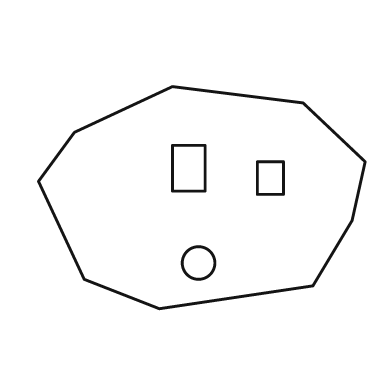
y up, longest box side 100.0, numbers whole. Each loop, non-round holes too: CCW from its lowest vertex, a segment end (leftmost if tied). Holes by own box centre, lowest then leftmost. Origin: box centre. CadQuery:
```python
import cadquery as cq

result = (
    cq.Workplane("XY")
    .moveTo(-13.0, -34.0)
    .lineTo(34.0, -27.0)
    .lineTo(46.0, -7.0)
    .lineTo(50.0, 11.0)
    .lineTo(31.0, 29.0)
    .lineTo(-9.0, 34.0)
    .lineTo(-39.0, 20.0)
    .lineTo(-50.0, 5.0)
    .lineTo(-36.0, -25.0)
    .close()
    .moveTo(-1.0, -20.0)
    .circle(5.0)
    .moveTo(17.0, 1.0)
    .lineTo(25.0, 1.0)
    .lineTo(25.0, 11.0)
    .lineTo(17.0, 11.0)
    .close()
    .moveTo(-9.0, 2.0)
    .lineTo(1.0, 2.0)
    .lineTo(1.0, 16.0)
    .lineTo(-9.0, 16.0)
    .close()
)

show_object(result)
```